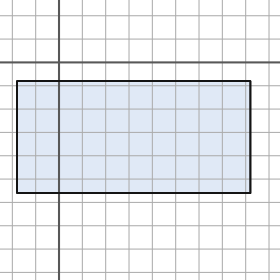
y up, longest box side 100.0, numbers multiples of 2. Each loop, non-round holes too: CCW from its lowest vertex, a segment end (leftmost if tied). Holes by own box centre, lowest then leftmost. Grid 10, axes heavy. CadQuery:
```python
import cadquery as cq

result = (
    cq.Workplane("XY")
    .moveTo(-18.0, -56.0)
    .lineTo(82.0, -56.0)
    .lineTo(82.0, -8.0)
    .lineTo(-18.0, -8.0)
    .close()
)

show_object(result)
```